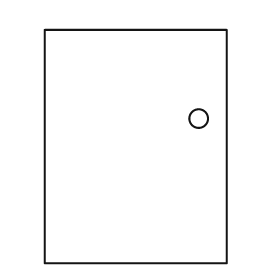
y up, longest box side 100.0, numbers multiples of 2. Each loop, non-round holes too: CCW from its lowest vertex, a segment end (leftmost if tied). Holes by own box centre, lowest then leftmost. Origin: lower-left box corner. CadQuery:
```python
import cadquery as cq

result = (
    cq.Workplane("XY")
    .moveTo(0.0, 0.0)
    .lineTo(78.0, 0.0)
    .lineTo(78.0, 100.0)
    .lineTo(0.0, 100.0)
    .close()
    .moveTo(66.0, 62.0)
    .circle(4.0)
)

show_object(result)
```